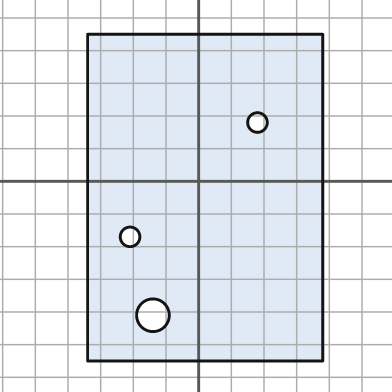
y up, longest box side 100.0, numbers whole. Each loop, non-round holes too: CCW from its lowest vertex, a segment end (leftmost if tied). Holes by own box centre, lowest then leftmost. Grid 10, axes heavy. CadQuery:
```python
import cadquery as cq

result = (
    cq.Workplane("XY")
    .moveTo(-34.0, -55.0)
    .lineTo(38.0, -55.0)
    .lineTo(38.0, 45.0)
    .lineTo(-34.0, 45.0)
    .close()
    .moveTo(-14.0, -41.0)
    .circle(5.0)
    .moveTo(-21.0, -17.0)
    .circle(3.0)
    .moveTo(18.0, 18.0)
    .circle(3.0)
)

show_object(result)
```